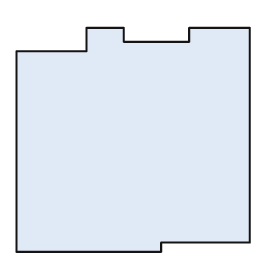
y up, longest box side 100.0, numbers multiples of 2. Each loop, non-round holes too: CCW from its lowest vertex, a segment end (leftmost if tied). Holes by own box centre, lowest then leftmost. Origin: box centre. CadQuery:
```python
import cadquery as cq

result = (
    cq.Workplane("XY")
    .moveTo(-50.0, -48.0)
    .lineTo(12.0, -48.0)
    .lineTo(12.0, -44.0)
    .lineTo(50.0, -44.0)
    .lineTo(50.0, 48.0)
    .lineTo(24.0, 48.0)
    .lineTo(24.0, 42.0)
    .lineTo(-4.0, 42.0)
    .lineTo(-4.0, 48.0)
    .lineTo(-20.0, 48.0)
    .lineTo(-20.0, 38.0)
    .lineTo(-50.0, 38.0)
    .close()
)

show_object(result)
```